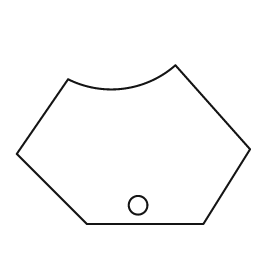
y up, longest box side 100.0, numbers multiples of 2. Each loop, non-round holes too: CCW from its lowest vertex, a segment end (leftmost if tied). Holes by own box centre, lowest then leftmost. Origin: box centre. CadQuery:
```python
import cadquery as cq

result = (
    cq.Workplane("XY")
    .moveTo(-20.0, -34.0)
    .lineTo(30.0, -34.0)
    .lineTo(50.0, -2.0)
    .lineTo(18.0, 34.0)
    .threePointArc((-4.0, 24.0), (-28.0, 28.0))
    .lineTo(-50.0, -4.0)
    .close()
    .moveTo(2.0, -26.0)
    .circle(4.0)
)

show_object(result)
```